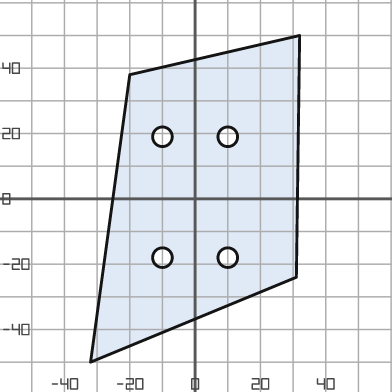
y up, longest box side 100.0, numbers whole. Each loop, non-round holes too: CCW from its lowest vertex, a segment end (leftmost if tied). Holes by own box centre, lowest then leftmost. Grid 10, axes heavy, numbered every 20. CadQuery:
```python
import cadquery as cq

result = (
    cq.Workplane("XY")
    .moveTo(-32.0, -50.0)
    .lineTo(31.0, -24.0)
    .lineTo(32.0, 50.0)
    .lineTo(-20.0, 38.0)
    .close()
    .moveTo(-10.0, -18.0)
    .circle(3.0)
    .moveTo(10.0, -18.0)
    .circle(3.0)
    .moveTo(-10.0, 19.0)
    .circle(3.0)
    .moveTo(10.0, 19.0)
    .circle(3.0)
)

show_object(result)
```